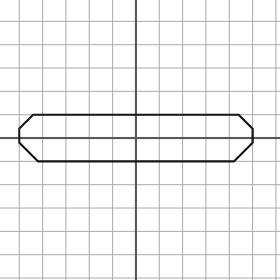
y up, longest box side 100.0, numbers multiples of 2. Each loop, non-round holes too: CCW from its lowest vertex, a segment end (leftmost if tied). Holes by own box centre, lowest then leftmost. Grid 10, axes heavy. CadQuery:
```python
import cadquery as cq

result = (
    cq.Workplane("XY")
    .moveTo(-42.0, -10.0)
    .lineTo(42.0, -10.0)
    .lineTo(50.0, -2.0)
    .lineTo(50.0, 4.0)
    .lineTo(44.0, 10.0)
    .lineTo(-44.0, 10.0)
    .lineTo(-50.0, 4.0)
    .lineTo(-50.0, -2.0)
    .close()
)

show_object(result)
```